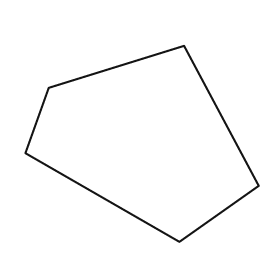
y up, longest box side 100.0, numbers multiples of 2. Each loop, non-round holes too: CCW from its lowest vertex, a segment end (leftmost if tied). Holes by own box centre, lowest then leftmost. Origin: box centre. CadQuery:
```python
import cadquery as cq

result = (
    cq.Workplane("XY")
    .moveTo(16.0, -42.0)
    .lineTo(50.0, -18.0)
    .lineTo(18.0, 42.0)
    .lineTo(-40.0, 24.0)
    .lineTo(-50.0, -4.0)
    .close()
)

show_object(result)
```